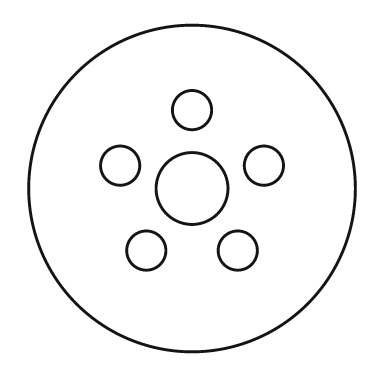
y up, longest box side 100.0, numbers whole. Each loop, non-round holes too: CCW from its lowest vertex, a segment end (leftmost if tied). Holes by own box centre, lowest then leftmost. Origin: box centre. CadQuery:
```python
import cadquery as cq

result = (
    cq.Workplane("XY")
    .moveTo(0.0, 0.0)
    .circle(50.0)
    .moveTo(-14.0, -19.0)
    .circle(6.0)
    .moveTo(14.0, -19.0)
    .circle(6.0)
    .moveTo(0.0, 0.0)
    .circle(11.0)
    .moveTo(-22.0, 7.0)
    .circle(6.0)
    .moveTo(22.0, 7.0)
    .circle(6.0)
    .moveTo(0.0, 24.0)
    .circle(6.0)
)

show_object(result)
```